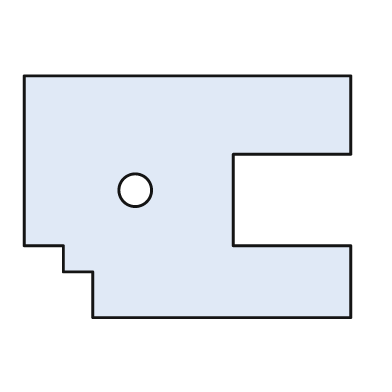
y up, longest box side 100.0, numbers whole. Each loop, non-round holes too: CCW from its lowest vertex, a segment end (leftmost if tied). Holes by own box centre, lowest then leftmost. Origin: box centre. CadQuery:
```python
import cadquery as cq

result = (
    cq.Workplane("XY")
    .moveTo(-29.0, -37.0)
    .lineTo(50.0, -37.0)
    .lineTo(50.0, -15.0)
    .lineTo(14.0, -15.0)
    .lineTo(14.0, 13.0)
    .lineTo(50.0, 13.0)
    .lineTo(50.0, 37.0)
    .lineTo(-50.0, 37.0)
    .lineTo(-50.0, -15.0)
    .lineTo(-38.0, -15.0)
    .lineTo(-38.0, -23.0)
    .lineTo(-29.0, -23.0)
    .close()
    .moveTo(-16.0, 2.0)
    .circle(5.0)
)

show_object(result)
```